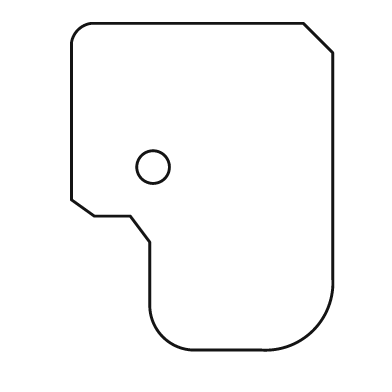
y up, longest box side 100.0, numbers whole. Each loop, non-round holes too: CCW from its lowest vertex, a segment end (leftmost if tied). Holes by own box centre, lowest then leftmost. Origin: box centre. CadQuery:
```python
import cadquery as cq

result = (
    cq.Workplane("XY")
    .moveTo(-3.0, -50.0)
    .lineTo(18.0, -50.0)
    .threePointArc((34.0, -44.0), (40.0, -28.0))
    .lineTo(40.0, 41.0)
    .lineTo(31.0, 50.0)
    .lineTo(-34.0, 50.0)
    .threePointArc((-38.0, 48.0), (-40.0, 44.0))
    .lineTo(-40.0, -4.0)
    .lineTo(-33.0, -9.0)
    .lineTo(-22.0, -9.0)
    .lineTo(-16.0, -17.0)
    .lineTo(-16.0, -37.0)
    .threePointArc((-12.0, -46.0), (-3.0, -50.0))
    .close()
    .moveTo(-15.0, 6.0)
    .circle(5.0)
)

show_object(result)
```